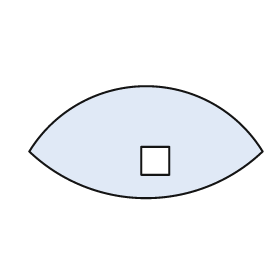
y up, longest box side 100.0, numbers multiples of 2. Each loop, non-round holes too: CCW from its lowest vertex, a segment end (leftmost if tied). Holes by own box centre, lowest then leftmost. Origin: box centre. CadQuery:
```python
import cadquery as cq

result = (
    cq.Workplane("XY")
    .moveTo(-50.0, -4.0)
    .threePointArc((0.0, -24.0), (50.0, -4.0))
    .threePointArc((0.0, 24.0), (-50.0, -4.0))
    .close()
    .moveTo(-2.0, -14.0)
    .lineTo(10.0, -14.0)
    .lineTo(10.0, -2.0)
    .lineTo(-2.0, -2.0)
    .close()
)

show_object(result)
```